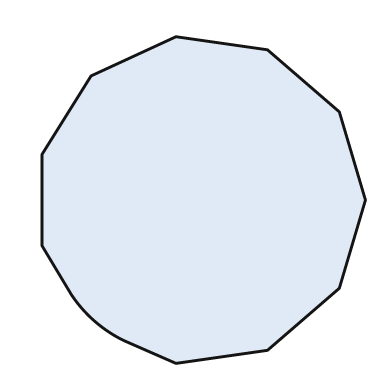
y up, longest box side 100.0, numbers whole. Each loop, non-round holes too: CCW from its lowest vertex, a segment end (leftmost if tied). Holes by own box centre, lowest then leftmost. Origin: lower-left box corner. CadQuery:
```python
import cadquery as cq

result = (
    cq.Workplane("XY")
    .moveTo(41.0, 0.0)
    .lineTo(69.0, 4.0)
    .lineTo(91.0, 23.0)
    .lineTo(99.0, 50.0)
    .lineTo(91.0, 77.0)
    .lineTo(69.0, 96.0)
    .lineTo(41.0, 100.0)
    .lineTo(15.0, 88.0)
    .lineTo(0.0, 64.0)
    .lineTo(0.0, 36.0)
    .lineTo(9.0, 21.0)
    .threePointArc((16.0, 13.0), (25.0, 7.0))
    .close()
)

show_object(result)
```